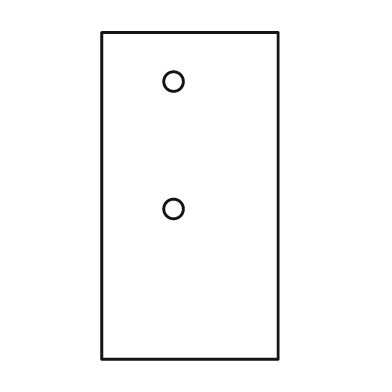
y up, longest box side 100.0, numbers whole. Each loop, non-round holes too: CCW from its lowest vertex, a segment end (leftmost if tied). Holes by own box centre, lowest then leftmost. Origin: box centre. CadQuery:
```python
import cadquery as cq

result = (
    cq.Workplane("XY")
    .moveTo(-27.0, -50.0)
    .lineTo(27.0, -50.0)
    .lineTo(27.0, 50.0)
    .lineTo(-27.0, 50.0)
    .close()
    .moveTo(-5.0, -4.0)
    .circle(3.0)
    .moveTo(-5.0, 35.0)
    .circle(3.0)
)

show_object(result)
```